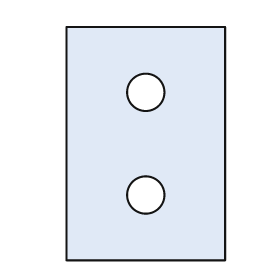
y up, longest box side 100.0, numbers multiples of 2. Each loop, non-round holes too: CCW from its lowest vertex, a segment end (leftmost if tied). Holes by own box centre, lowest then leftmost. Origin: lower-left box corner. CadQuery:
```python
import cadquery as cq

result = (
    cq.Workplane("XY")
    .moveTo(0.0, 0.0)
    .lineTo(68.0, 0.0)
    .lineTo(68.0, 100.0)
    .lineTo(0.0, 100.0)
    .close()
    .moveTo(34.0, 28.0)
    .circle(8.0)
    .moveTo(34.0, 72.0)
    .circle(8.0)
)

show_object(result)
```